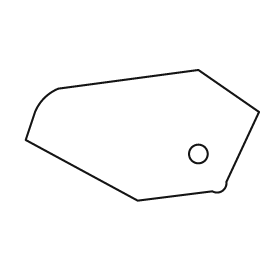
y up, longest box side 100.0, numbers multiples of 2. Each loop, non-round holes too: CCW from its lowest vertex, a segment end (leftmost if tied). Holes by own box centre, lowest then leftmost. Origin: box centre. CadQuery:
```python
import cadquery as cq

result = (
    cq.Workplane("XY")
    .moveTo(-2.0, -28.0)
    .lineTo(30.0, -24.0)
    .threePointArc((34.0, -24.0), (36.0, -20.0))
    .lineTo(50.0, 10.0)
    .lineTo(24.0, 28.0)
    .lineTo(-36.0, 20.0)
    .threePointArc((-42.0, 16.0), (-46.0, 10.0))
    .lineTo(-50.0, -2.0)
    .close()
    .moveTo(24.0, -8.0)
    .circle(4.0)
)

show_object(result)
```